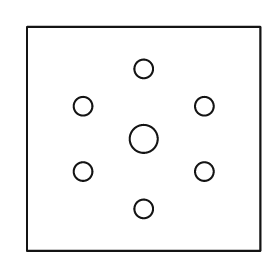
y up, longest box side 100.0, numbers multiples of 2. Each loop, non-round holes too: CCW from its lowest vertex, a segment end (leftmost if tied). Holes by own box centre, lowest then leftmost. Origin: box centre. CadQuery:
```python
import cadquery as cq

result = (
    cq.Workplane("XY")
    .moveTo(-50.0, -48.0)
    .lineTo(50.0, -48.0)
    .lineTo(50.0, 48.0)
    .lineTo(-50.0, 48.0)
    .close()
    .moveTo(0.0, -30.0)
    .circle(4.0)
    .moveTo(-26.0, -14.0)
    .circle(4.0)
    .moveTo(26.0, -14.0)
    .circle(4.0)
    .moveTo(0.0, 0.0)
    .circle(6.0)
    .moveTo(-26.0, 14.0)
    .circle(4.0)
    .moveTo(26.0, 14.0)
    .circle(4.0)
    .moveTo(0.0, 30.0)
    .circle(4.0)
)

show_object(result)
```